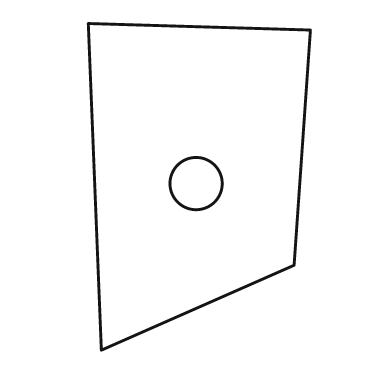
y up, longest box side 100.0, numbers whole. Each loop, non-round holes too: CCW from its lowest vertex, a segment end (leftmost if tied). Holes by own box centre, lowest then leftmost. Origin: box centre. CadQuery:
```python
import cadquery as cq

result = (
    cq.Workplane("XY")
    .moveTo(-30.0, -50.0)
    .lineTo(29.0, -24.0)
    .lineTo(34.0, 48.0)
    .lineTo(-34.0, 50.0)
    .close()
    .moveTo(-1.0, 1.0)
    .circle(8.0)
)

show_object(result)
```